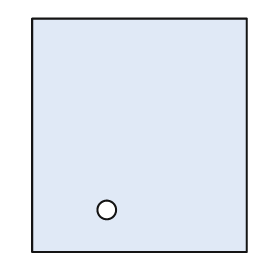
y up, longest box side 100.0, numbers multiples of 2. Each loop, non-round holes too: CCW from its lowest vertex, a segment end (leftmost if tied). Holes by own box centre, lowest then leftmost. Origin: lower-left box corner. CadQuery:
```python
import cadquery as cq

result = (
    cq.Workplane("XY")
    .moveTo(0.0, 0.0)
    .lineTo(92.0, 0.0)
    .lineTo(92.0, 100.0)
    .lineTo(0.0, 100.0)
    .close()
    .moveTo(32.0, 18.0)
    .circle(4.0)
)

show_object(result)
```